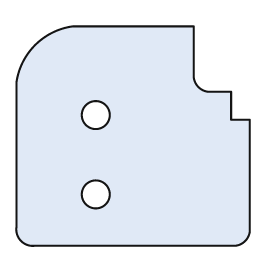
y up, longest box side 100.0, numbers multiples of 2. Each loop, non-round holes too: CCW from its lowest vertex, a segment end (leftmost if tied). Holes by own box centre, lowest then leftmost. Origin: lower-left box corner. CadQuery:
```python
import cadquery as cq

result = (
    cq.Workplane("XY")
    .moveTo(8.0, 0.0)
    .lineTo(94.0, 0.0)
    .threePointArc((98.0, 2.0), (100.0, 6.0))
    .lineTo(100.0, 54.0)
    .lineTo(92.0, 54.0)
    .lineTo(92.0, 66.0)
    .lineTo(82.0, 66.0)
    .threePointArc((78.0, 68.0), (76.0, 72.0))
    .lineTo(76.0, 94.0)
    .lineTo(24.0, 94.0)
    .threePointArc((8.0, 86.0), (0.0, 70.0))
    .lineTo(0.0, 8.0)
    .threePointArc((2.0, 2.0), (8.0, 0.0))
    .close()
    .moveTo(34.0, 22.0)
    .circle(6.0)
    .moveTo(34.0, 56.0)
    .circle(6.0)
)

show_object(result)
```